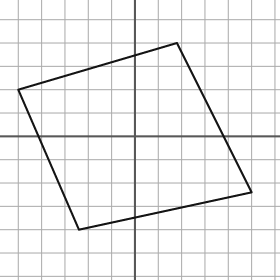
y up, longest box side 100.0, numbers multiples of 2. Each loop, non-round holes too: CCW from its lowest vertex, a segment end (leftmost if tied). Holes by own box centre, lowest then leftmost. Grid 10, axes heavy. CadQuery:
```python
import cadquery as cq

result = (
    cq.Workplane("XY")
    .moveTo(-24.0, -40.0)
    .lineTo(50.0, -24.0)
    .lineTo(18.0, 40.0)
    .lineTo(-50.0, 20.0)
    .close()
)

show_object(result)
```